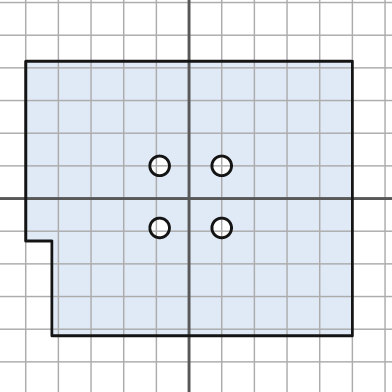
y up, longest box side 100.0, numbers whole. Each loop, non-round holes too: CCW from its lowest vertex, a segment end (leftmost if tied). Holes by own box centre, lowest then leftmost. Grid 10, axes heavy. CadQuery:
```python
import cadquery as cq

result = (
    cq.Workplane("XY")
    .moveTo(-42.0, -42.0)
    .lineTo(50.0, -42.0)
    .lineTo(50.0, 42.0)
    .lineTo(-50.0, 42.0)
    .lineTo(-50.0, -13.0)
    .lineTo(-42.0, -13.0)
    .close()
    .moveTo(-9.0, -9.0)
    .circle(3.0)
    .moveTo(10.0, -9.0)
    .circle(3.0)
    .moveTo(-9.0, 10.0)
    .circle(3.0)
    .moveTo(10.0, 10.0)
    .circle(3.0)
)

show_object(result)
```